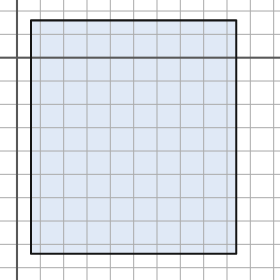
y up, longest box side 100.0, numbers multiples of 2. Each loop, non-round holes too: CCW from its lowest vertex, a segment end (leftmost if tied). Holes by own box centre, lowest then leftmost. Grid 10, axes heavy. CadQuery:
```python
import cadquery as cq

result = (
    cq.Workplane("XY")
    .moveTo(6.0, -84.0)
    .lineTo(94.0, -84.0)
    .lineTo(94.0, 16.0)
    .lineTo(6.0, 16.0)
    .close()
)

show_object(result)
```